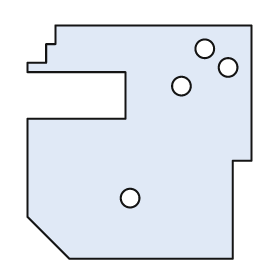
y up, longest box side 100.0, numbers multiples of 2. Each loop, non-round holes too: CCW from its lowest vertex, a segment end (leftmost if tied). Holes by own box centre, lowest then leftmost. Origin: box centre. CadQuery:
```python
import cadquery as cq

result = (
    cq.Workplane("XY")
    .moveTo(-30.0, -50.0)
    .lineTo(40.0, -50.0)
    .lineTo(40.0, -8.0)
    .lineTo(48.0, -8.0)
    .lineTo(48.0, 50.0)
    .lineTo(-36.0, 50.0)
    .lineTo(-36.0, 42.0)
    .lineTo(-40.0, 42.0)
    .lineTo(-40.0, 34.0)
    .lineTo(-48.0, 34.0)
    .lineTo(-48.0, 30.0)
    .lineTo(-6.0, 30.0)
    .lineTo(-6.0, 10.0)
    .lineTo(-48.0, 10.0)
    .lineTo(-48.0, -32.0)
    .close()
    .moveTo(-4.0, -24.0)
    .circle(4.0)
    .moveTo(18.0, 24.0)
    .circle(4.0)
    .moveTo(38.0, 32.0)
    .circle(4.0)
    .moveTo(28.0, 40.0)
    .circle(4.0)
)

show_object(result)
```